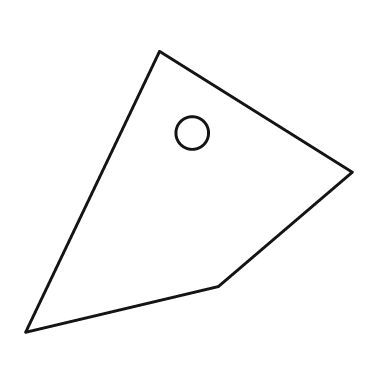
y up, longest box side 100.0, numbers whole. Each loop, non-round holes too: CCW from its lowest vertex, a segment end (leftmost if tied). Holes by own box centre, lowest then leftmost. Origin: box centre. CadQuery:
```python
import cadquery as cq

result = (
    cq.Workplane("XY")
    .moveTo(-50.0, -43.0)
    .lineTo(9.0, -29.0)
    .lineTo(50.0, 6.0)
    .lineTo(-9.0, 43.0)
    .close()
    .moveTo(1.0, 18.0)
    .circle(5.0)
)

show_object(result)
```